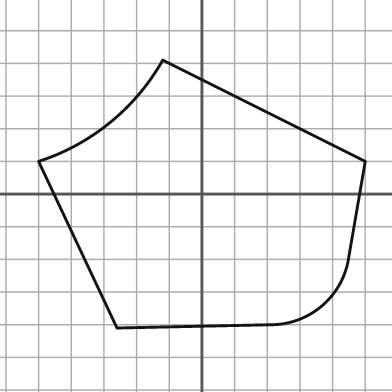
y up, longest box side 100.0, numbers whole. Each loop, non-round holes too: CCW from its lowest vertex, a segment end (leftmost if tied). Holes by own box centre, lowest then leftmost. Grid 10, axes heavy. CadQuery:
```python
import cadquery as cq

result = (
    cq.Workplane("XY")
    .moveTo(-26.0, -41.0)
    .lineTo(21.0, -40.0)
    .threePointArc((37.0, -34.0), (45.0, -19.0))
    .lineTo(50.0, 10.0)
    .lineTo(-12.0, 41.0)
    .threePointArc((-28.0, 22.0), (-50.0, 10.0))
    .close()
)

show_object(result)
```